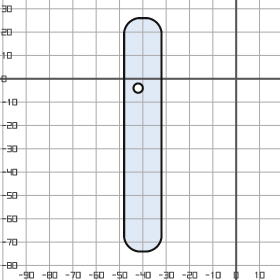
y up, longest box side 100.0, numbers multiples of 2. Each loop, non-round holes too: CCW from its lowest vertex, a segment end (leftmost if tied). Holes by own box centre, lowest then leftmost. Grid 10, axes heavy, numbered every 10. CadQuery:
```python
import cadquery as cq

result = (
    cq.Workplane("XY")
    .moveTo(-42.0, -74.0)
    .lineTo(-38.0, -74.0)
    .threePointArc((-34.0, -72.0), (-32.0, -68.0))
    .lineTo(-32.0, 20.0)
    .threePointArc((-34.0, 24.0), (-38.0, 26.0))
    .lineTo(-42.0, 26.0)
    .threePointArc((-46.0, 24.0), (-48.0, 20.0))
    .lineTo(-48.0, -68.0)
    .threePointArc((-46.0, -72.0), (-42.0, -74.0))
    .close()
    .moveTo(-42.0, -4.0)
    .circle(2.0)
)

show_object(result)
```